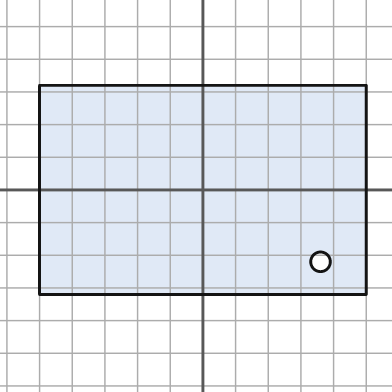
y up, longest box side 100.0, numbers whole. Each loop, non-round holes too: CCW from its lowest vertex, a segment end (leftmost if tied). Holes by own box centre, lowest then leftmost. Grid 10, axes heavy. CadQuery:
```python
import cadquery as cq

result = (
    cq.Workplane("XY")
    .moveTo(-50.0, -32.0)
    .lineTo(50.0, -32.0)
    .lineTo(50.0, 32.0)
    .lineTo(-50.0, 32.0)
    .close()
    .moveTo(36.0, -22.0)
    .circle(3.0)
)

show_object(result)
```